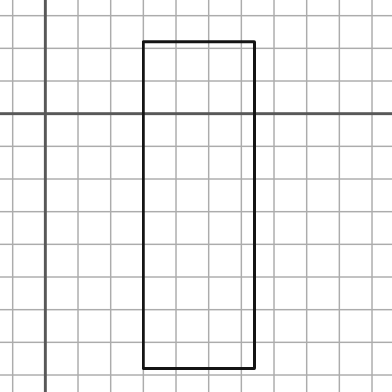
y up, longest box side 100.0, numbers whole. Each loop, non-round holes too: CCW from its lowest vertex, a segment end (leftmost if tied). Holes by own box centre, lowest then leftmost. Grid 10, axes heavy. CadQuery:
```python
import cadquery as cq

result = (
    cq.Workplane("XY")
    .moveTo(30.0, -78.0)
    .lineTo(64.0, -78.0)
    .lineTo(64.0, 22.0)
    .lineTo(30.0, 22.0)
    .close()
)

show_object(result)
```